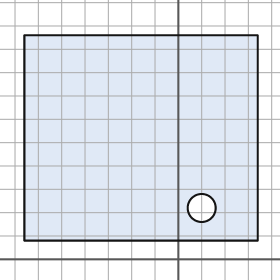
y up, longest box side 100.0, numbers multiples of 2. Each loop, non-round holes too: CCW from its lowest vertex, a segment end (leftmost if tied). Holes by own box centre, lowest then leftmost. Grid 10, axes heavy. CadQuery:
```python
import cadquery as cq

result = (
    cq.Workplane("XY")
    .moveTo(-66.0, 8.0)
    .lineTo(34.0, 8.0)
    .lineTo(34.0, 96.0)
    .lineTo(-66.0, 96.0)
    .close()
    .moveTo(10.0, 22.0)
    .circle(6.0)
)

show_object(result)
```